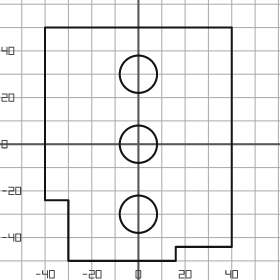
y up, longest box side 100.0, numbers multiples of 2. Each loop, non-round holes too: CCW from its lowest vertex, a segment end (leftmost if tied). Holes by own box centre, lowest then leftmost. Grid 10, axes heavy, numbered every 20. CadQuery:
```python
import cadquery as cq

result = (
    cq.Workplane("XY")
    .moveTo(-30.0, -50.0)
    .lineTo(16.0, -50.0)
    .lineTo(16.0, -44.0)
    .lineTo(40.0, -44.0)
    .lineTo(40.0, 50.0)
    .lineTo(-40.0, 50.0)
    .lineTo(-40.0, -24.0)
    .lineTo(-30.0, -24.0)
    .close()
    .moveTo(0.0, -30.0)
    .circle(8.0)
    .moveTo(0.0, 0.0)
    .circle(8.0)
    .moveTo(0.0, 30.0)
    .circle(8.0)
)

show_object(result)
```